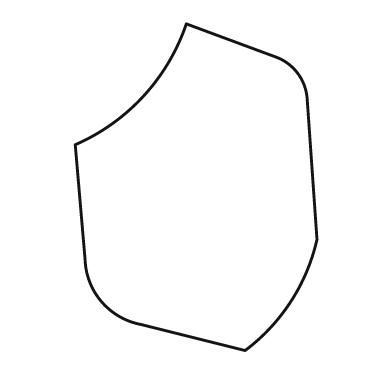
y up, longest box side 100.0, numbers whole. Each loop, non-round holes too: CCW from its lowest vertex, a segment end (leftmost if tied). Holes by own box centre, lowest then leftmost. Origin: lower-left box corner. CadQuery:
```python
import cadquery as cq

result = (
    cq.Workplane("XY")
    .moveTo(52.0, 0.0)
    .threePointArc((66.0, 15.0), (74.0, 34.0))
    .lineTo(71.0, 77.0)
    .threePointArc((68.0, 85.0), (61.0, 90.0))
    .lineTo(34.0, 100.0)
    .threePointArc((21.0, 78.0), (0.0, 63.0))
    .lineTo(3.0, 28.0)
    .threePointArc((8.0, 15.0), (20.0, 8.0))
    .close()
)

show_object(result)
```